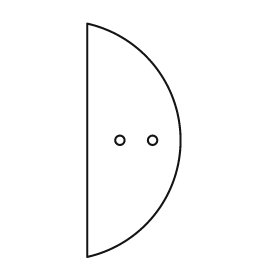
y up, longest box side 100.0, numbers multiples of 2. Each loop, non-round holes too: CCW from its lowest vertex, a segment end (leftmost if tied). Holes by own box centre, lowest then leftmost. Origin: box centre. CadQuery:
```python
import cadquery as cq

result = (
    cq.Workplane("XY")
    .moveTo(-20.0, -50.0)
    .threePointArc((20.0, 0.0), (-20.0, 50.0))
    .close()
    .moveTo(-6.0, 0.0)
    .circle(2.0)
    .moveTo(8.0, 0.0)
    .circle(2.0)
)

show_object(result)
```